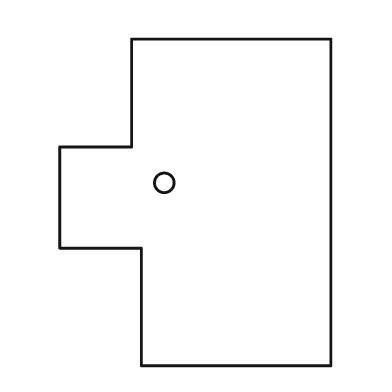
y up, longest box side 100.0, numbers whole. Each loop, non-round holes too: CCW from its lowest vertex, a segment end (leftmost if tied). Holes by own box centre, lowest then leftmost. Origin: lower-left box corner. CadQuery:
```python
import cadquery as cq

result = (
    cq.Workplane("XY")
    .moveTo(25.0, 0.0)
    .lineTo(83.0, 0.0)
    .lineTo(83.0, 100.0)
    .lineTo(22.0, 100.0)
    .lineTo(22.0, 67.0)
    .lineTo(0.0, 67.0)
    .lineTo(0.0, 36.0)
    .lineTo(25.0, 36.0)
    .close()
    .moveTo(32.0, 56.0)
    .circle(3.0)
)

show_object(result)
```